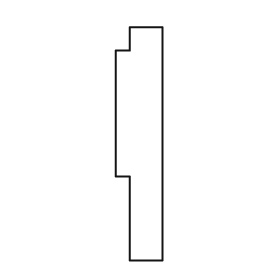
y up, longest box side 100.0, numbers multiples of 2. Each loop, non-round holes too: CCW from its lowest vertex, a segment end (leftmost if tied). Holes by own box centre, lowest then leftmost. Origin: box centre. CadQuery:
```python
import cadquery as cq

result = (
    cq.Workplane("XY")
    .moveTo(-4.0, -50.0)
    .lineTo(10.0, -50.0)
    .lineTo(10.0, 50.0)
    .lineTo(-4.0, 50.0)
    .lineTo(-4.0, 40.0)
    .lineTo(-10.0, 40.0)
    .lineTo(-10.0, -14.0)
    .lineTo(-4.0, -14.0)
    .close()
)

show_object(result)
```